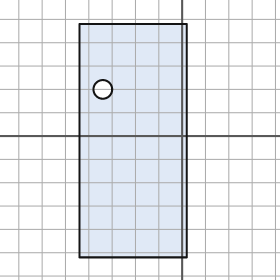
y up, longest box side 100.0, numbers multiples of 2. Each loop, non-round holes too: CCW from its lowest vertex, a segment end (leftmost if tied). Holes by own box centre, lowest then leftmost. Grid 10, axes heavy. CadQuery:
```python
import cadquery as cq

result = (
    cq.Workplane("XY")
    .moveTo(-44.0, -52.0)
    .lineTo(2.0, -52.0)
    .lineTo(2.0, 48.0)
    .lineTo(-44.0, 48.0)
    .close()
    .moveTo(-34.0, 20.0)
    .circle(4.0)
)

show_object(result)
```